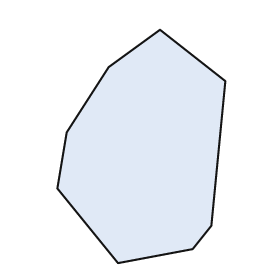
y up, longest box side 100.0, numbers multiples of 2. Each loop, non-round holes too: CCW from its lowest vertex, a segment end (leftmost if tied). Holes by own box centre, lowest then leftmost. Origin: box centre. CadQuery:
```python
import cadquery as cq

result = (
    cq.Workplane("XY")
    .moveTo(-10.0, -50.0)
    .lineTo(22.0, -44.0)
    .lineTo(30.0, -34.0)
    .lineTo(36.0, 28.0)
    .lineTo(8.0, 50.0)
    .lineTo(-14.0, 34.0)
    .lineTo(-32.0, 6.0)
    .lineTo(-36.0, -18.0)
    .close()
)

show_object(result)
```